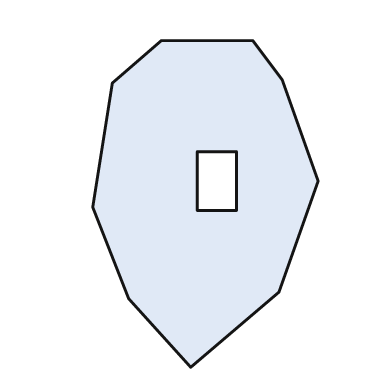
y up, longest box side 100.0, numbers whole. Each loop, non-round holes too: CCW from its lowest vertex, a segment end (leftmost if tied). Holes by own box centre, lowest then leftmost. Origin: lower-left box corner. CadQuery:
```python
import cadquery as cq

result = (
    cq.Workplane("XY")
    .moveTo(30.0, 0.0)
    .lineTo(57.0, 23.0)
    .lineTo(69.0, 57.0)
    .lineTo(58.0, 88.0)
    .lineTo(49.0, 100.0)
    .lineTo(21.0, 100.0)
    .lineTo(6.0, 87.0)
    .lineTo(0.0, 49.0)
    .lineTo(11.0, 21.0)
    .close()
    .moveTo(32.0, 48.0)
    .lineTo(44.0, 48.0)
    .lineTo(44.0, 66.0)
    .lineTo(32.0, 66.0)
    .close()
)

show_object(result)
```